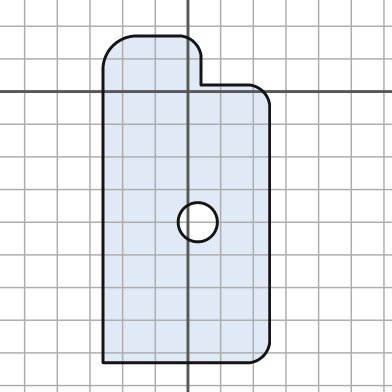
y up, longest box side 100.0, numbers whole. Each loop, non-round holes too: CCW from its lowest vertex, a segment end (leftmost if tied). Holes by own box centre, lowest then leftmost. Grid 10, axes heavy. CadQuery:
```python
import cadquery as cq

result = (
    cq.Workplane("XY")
    .moveTo(-26.0, -83.0)
    .lineTo(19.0, -83.0)
    .threePointArc((23.0, -81.0), (25.0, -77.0))
    .lineTo(25.0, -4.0)
    .threePointArc((23.0, 0.0), (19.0, 2.0))
    .lineTo(4.0, 2.0)
    .lineTo(4.0, 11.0)
    .threePointArc((2.0, 15.0), (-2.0, 17.0))
    .lineTo(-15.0, 17.0)
    .threePointArc((-23.0, 14.0), (-26.0, 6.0))
    .close()
    .moveTo(3.0, -40.0)
    .circle(6.0)
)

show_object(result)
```